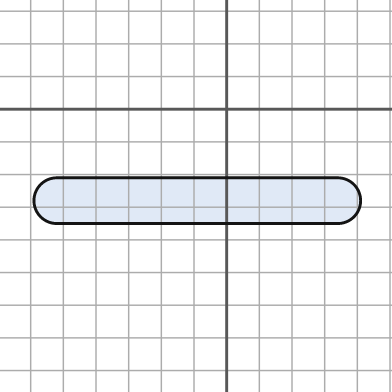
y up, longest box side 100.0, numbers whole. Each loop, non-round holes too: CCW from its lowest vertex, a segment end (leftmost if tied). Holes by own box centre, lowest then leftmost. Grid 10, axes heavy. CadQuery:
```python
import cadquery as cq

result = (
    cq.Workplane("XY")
    .moveTo(-52.0, -35.0)
    .lineTo(34.0, -35.0)
    .threePointArc((41.0, -28.0), (34.0, -21.0))
    .lineTo(-52.0, -21.0)
    .threePointArc((-59.0, -28.0), (-52.0, -35.0))
    .close()
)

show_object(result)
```